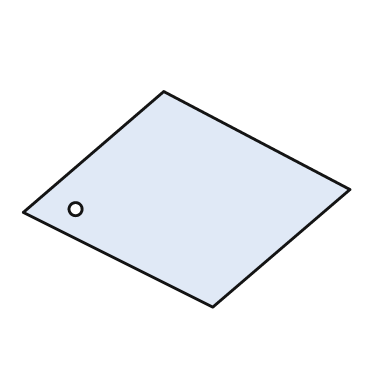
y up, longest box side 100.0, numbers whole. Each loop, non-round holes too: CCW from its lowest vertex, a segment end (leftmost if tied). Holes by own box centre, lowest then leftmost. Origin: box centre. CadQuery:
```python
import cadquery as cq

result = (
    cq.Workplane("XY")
    .moveTo(8.0, -33.0)
    .lineTo(50.0, 3.0)
    .lineTo(-7.0, 33.0)
    .lineTo(-50.0, -4.0)
    .close()
    .moveTo(-34.0, -3.0)
    .circle(2.0)
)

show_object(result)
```